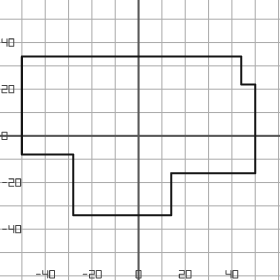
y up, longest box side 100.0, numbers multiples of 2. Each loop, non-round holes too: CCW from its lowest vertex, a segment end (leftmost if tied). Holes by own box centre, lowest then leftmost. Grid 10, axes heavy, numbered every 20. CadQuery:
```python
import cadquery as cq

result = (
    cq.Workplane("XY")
    .moveTo(-28.0, -34.0)
    .lineTo(14.0, -34.0)
    .lineTo(14.0, -16.0)
    .lineTo(50.0, -16.0)
    .lineTo(50.0, 22.0)
    .lineTo(44.0, 22.0)
    .lineTo(44.0, 34.0)
    .lineTo(-50.0, 34.0)
    .lineTo(-50.0, -8.0)
    .lineTo(-28.0, -8.0)
    .close()
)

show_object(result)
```